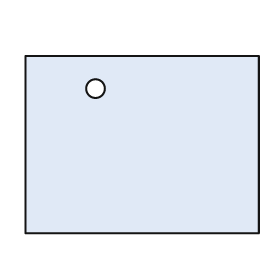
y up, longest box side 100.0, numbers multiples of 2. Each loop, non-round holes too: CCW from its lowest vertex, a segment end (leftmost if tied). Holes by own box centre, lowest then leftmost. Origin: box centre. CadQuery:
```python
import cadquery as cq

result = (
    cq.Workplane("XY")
    .moveTo(-50.0, -38.0)
    .lineTo(50.0, -38.0)
    .lineTo(50.0, 38.0)
    .lineTo(-50.0, 38.0)
    .close()
    .moveTo(-20.0, 24.0)
    .circle(4.0)
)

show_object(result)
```